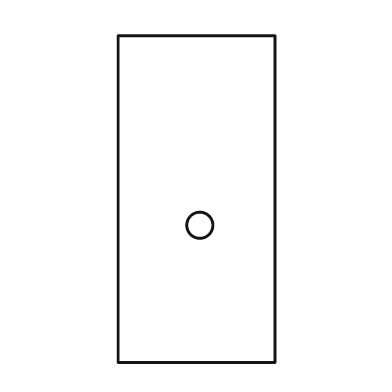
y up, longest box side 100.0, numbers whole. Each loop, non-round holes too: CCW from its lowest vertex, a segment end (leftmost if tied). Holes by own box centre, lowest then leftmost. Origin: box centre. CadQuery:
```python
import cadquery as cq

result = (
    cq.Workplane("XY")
    .moveTo(-24.0, -50.0)
    .lineTo(24.0, -50.0)
    .lineTo(24.0, 50.0)
    .lineTo(-24.0, 50.0)
    .close()
    .moveTo(1.0, -8.0)
    .circle(4.0)
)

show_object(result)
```